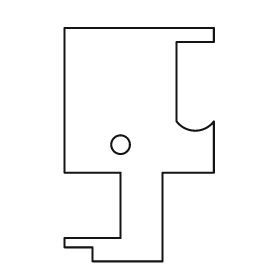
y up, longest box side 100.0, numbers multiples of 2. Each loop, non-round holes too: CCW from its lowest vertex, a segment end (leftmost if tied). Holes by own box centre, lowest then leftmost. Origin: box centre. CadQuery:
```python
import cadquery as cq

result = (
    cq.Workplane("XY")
    .moveTo(-20.0, -50.0)
    .lineTo(10.0, -50.0)
    .lineTo(10.0, -12.0)
    .lineTo(32.0, -12.0)
    .lineTo(32.0, 10.0)
    .threePointArc((24.0, 6.0), (16.0, 10.0))
    .lineTo(16.0, 44.0)
    .lineTo(32.0, 44.0)
    .lineTo(32.0, 50.0)
    .lineTo(-32.0, 50.0)
    .lineTo(-32.0, -12.0)
    .lineTo(-8.0, -12.0)
    .lineTo(-8.0, -40.0)
    .lineTo(-32.0, -40.0)
    .lineTo(-32.0, -44.0)
    .lineTo(-20.0, -44.0)
    .close()
    .moveTo(-8.0, 0.0)
    .circle(4.0)
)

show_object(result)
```